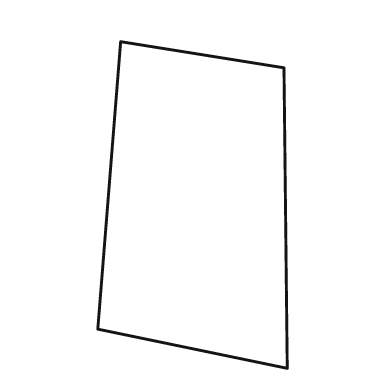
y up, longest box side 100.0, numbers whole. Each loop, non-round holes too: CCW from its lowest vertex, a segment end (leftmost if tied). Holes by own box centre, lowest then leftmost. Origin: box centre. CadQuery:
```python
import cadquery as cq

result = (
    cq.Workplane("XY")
    .moveTo(29.0, -50.0)
    .lineTo(28.0, 42.0)
    .lineTo(-22.0, 50.0)
    .lineTo(-29.0, -38.0)
    .close()
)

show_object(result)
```